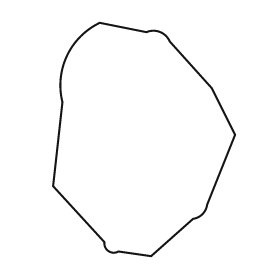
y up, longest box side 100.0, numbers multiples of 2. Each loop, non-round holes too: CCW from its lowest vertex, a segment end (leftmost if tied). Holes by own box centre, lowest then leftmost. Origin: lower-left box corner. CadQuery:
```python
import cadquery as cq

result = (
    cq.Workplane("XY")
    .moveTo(42.0, 0.0)
    .lineTo(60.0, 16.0)
    .threePointArc((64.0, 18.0), (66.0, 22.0))
    .lineTo(78.0, 52.0)
    .lineTo(68.0, 72.0)
    .lineTo(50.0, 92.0)
    .threePointArc((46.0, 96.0), (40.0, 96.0))
    .lineTo(20.0, 100.0)
    .threePointArc((6.0, 86.0), (4.0, 66.0))
    .lineTo(0.0, 30.0)
    .lineTo(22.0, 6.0)
    .threePointArc((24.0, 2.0), (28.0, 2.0))
    .close()
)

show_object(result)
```